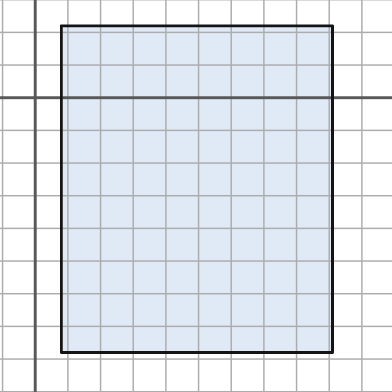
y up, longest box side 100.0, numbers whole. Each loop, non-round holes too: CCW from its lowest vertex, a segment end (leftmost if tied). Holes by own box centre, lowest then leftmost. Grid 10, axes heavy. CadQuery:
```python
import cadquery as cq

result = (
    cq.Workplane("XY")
    .moveTo(8.0, -78.0)
    .lineTo(91.0, -78.0)
    .lineTo(91.0, 22.0)
    .lineTo(8.0, 22.0)
    .close()
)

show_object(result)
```